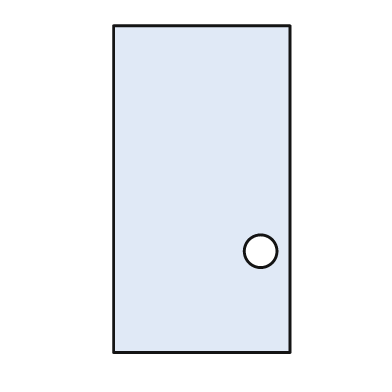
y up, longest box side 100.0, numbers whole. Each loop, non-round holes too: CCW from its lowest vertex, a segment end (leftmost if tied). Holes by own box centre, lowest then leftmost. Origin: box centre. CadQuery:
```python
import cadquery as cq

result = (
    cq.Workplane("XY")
    .moveTo(-27.0, -50.0)
    .lineTo(27.0, -50.0)
    .lineTo(27.0, 50.0)
    .lineTo(-27.0, 50.0)
    .close()
    .moveTo(18.0, -19.0)
    .circle(5.0)
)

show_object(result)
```